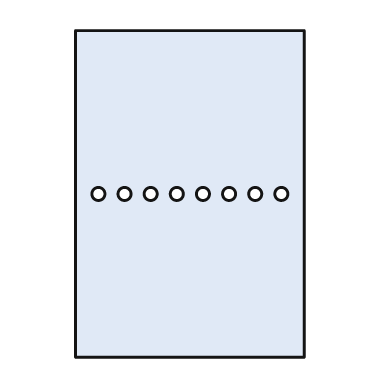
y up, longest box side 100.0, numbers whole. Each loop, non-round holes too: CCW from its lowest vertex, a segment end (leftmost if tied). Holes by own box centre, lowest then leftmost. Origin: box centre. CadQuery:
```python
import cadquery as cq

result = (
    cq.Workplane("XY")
    .moveTo(-35.0, -50.0)
    .lineTo(35.0, -50.0)
    .lineTo(35.0, 50.0)
    .lineTo(-35.0, 50.0)
    .close()
    .moveTo(-28.0, 0.0)
    .circle(2.0)
    .moveTo(-20.0, 0.0)
    .circle(2.0)
    .moveTo(-12.0, 0.0)
    .circle(2.0)
    .moveTo(-4.0, 0.0)
    .circle(2.0)
    .moveTo(4.0, 0.0)
    .circle(2.0)
    .moveTo(12.0, 0.0)
    .circle(2.0)
    .moveTo(20.0, 0.0)
    .circle(2.0)
    .moveTo(28.0, 0.0)
    .circle(2.0)
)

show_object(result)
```